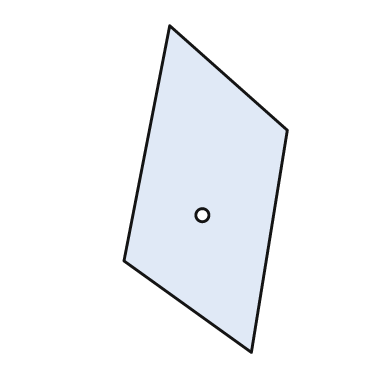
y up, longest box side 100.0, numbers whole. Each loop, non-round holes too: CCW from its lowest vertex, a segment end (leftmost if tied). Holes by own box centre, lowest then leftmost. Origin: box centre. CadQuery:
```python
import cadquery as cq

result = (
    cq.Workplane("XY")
    .moveTo(14.0, -50.0)
    .lineTo(25.0, 18.0)
    .lineTo(-11.0, 50.0)
    .lineTo(-25.0, -22.0)
    .close()
    .moveTo(-1.0, -8.0)
    .circle(2.0)
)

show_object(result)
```